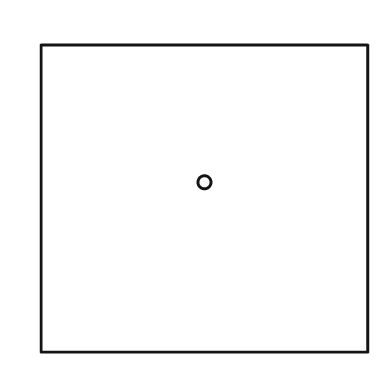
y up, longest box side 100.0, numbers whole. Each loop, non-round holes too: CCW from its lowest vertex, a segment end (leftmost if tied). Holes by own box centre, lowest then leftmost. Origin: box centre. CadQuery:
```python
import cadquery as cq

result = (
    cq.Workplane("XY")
    .moveTo(-50.0, -47.0)
    .lineTo(50.0, -47.0)
    .lineTo(50.0, 47.0)
    .lineTo(-50.0, 47.0)
    .close()
    .moveTo(0.0, 5.0)
    .circle(2.0)
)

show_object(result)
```